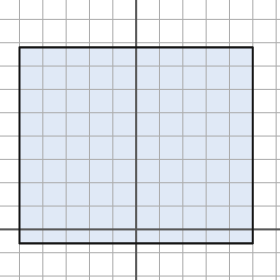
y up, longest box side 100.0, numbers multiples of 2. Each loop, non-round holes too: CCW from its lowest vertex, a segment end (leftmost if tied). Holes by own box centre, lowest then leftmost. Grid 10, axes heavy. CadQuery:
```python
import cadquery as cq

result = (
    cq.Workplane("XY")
    .moveTo(-50.0, -6.0)
    .lineTo(50.0, -6.0)
    .lineTo(50.0, 78.0)
    .lineTo(-50.0, 78.0)
    .close()
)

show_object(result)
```